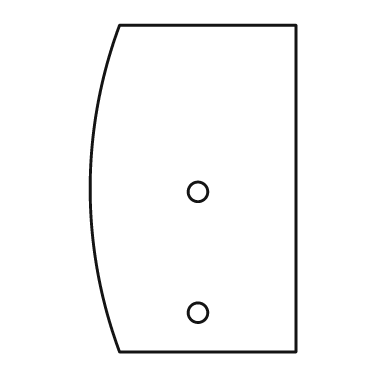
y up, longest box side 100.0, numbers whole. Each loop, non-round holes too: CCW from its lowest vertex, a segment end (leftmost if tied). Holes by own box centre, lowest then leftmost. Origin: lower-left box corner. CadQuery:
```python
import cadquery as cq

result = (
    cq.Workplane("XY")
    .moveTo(9.0, 0.0)
    .lineTo(63.0, 0.0)
    .lineTo(63.0, 100.0)
    .lineTo(9.0, 100.0)
    .threePointArc((0.0, 50.0), (9.0, 0.0))
    .close()
    .moveTo(33.0, 12.0)
    .circle(3.0)
    .moveTo(33.0, 49.0)
    .circle(3.0)
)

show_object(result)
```